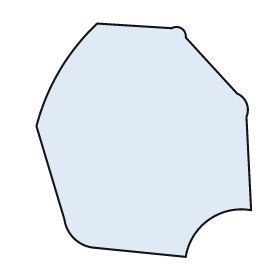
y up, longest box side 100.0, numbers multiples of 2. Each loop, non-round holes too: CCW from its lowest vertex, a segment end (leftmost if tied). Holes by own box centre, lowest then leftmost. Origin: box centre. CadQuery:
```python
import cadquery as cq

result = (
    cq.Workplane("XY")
    .moveTo(18.0, -50.0)
    .threePointArc((28.0, -34.0), (46.0, -30.0))
    .lineTo(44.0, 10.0)
    .threePointArc((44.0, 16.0), (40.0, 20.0))
    .lineTo(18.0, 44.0)
    .threePointArc((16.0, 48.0), (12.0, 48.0))
    .lineTo(-20.0, 50.0)
    .threePointArc((-36.0, 30.0), (-46.0, 6.0))
    .lineTo(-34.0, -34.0)
    .threePointArc((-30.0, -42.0), (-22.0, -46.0))
    .close()
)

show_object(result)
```